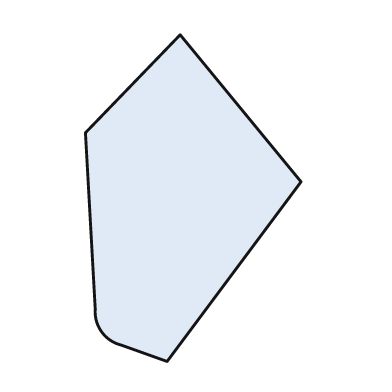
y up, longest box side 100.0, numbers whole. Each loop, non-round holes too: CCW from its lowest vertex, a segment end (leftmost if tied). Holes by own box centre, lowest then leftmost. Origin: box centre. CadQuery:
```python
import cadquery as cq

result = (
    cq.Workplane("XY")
    .moveTo(-8.0, -50.0)
    .lineTo(33.0, 5.0)
    .lineTo(-4.0, 50.0)
    .lineTo(-33.0, 20.0)
    .lineTo(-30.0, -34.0)
    .threePointArc((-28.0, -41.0), (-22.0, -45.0))
    .close()
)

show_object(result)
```